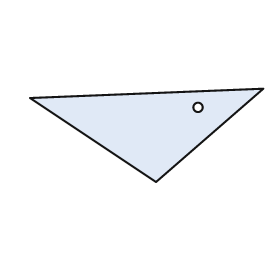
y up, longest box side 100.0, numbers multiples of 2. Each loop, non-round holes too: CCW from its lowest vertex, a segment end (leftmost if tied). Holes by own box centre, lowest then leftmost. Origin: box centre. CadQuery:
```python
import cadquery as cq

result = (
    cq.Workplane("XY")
    .moveTo(4.0, -20.0)
    .lineTo(50.0, 20.0)
    .lineTo(-50.0, 16.0)
    .close()
    .moveTo(22.0, 12.0)
    .circle(2.0)
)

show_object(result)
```